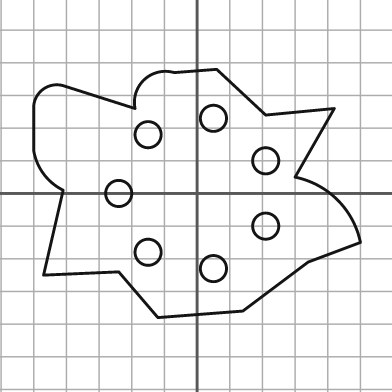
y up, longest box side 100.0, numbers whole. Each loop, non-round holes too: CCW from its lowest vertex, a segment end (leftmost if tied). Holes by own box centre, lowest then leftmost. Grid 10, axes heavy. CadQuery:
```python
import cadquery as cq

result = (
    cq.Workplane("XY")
    .moveTo(-12.0, -38.0)
    .lineTo(14.0, -36.0)
    .lineTo(34.0, -21.0)
    .lineTo(50.0, -15.0)
    .threePointArc((43.0, -2.0), (30.0, 5.0))
    .lineTo(42.0, 26.0)
    .lineTo(21.0, 24.0)
    .lineTo(6.0, 38.0)
    .lineTo(-7.0, 37.0)
    .threePointArc((-16.0, 35.0), (-19.0, 26.0))
    .lineTo(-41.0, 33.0)
    .threePointArc((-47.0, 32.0), (-50.0, 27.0))
    .lineTo(-50.0, 13.0)
    .threePointArc((-47.0, 6.0), (-41.0, 1.0))
    .lineTo(-47.0, -25.0)
    .lineTo(-24.0, -24.0)
    .close()
    .moveTo(5.0, -23.0)
    .circle(4.0)
    .moveTo(-15.0, -18.0)
    .circle(4.0)
    .moveTo(21.0, -10.0)
    .circle(4.0)
    .moveTo(-24.0, 0.0)
    .circle(4.0)
    .moveTo(21.0, 10.0)
    .circle(4.0)
    .moveTo(-15.0, 18.0)
    .circle(4.0)
    .moveTo(5.0, 23.0)
    .circle(4.0)
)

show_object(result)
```